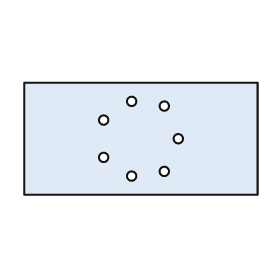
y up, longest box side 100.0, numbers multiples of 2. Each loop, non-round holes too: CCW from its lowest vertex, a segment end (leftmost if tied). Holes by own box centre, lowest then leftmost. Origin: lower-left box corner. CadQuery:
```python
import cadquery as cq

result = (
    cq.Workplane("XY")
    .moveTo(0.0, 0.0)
    .lineTo(100.0, 0.0)
    .lineTo(100.0, 48.0)
    .lineTo(0.0, 48.0)
    .close()
    .moveTo(46.0, 8.0)
    .circle(2.0)
    .moveTo(60.0, 10.0)
    .circle(2.0)
    .moveTo(34.0, 16.0)
    .circle(2.0)
    .moveTo(66.0, 24.0)
    .circle(2.0)
    .moveTo(34.0, 32.0)
    .circle(2.0)
    .moveTo(60.0, 38.0)
    .circle(2.0)
    .moveTo(46.0, 40.0)
    .circle(2.0)
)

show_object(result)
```